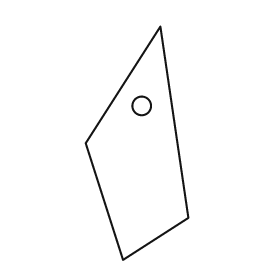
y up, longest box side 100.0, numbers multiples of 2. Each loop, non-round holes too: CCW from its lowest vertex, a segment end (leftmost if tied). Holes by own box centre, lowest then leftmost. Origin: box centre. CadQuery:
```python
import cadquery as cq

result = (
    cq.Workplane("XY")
    .moveTo(-6.0, -50.0)
    .lineTo(22.0, -32.0)
    .lineTo(10.0, 50.0)
    .lineTo(-22.0, 0.0)
    .close()
    .moveTo(2.0, 16.0)
    .circle(4.0)
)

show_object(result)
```